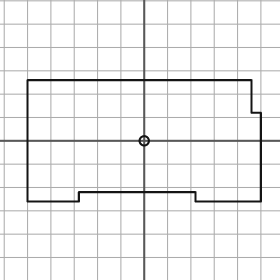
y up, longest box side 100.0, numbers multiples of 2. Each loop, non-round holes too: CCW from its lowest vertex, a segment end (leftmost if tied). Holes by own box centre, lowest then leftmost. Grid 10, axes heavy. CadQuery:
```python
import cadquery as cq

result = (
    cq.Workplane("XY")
    .moveTo(-50.0, -26.0)
    .lineTo(-28.0, -26.0)
    .lineTo(-28.0, -22.0)
    .lineTo(22.0, -22.0)
    .lineTo(22.0, -26.0)
    .lineTo(50.0, -26.0)
    .lineTo(50.0, 12.0)
    .lineTo(46.0, 12.0)
    .lineTo(46.0, 26.0)
    .lineTo(-50.0, 26.0)
    .close()
    .moveTo(0.0, 0.0)
    .circle(2.0)
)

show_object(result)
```